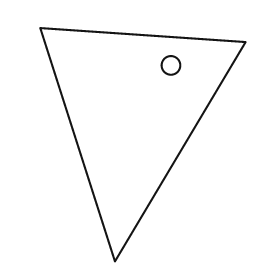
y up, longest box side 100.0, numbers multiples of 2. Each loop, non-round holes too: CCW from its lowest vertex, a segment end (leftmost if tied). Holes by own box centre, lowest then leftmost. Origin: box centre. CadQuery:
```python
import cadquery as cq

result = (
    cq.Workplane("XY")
    .moveTo(-12.0, -50.0)
    .lineTo(44.0, 44.0)
    .lineTo(-44.0, 50.0)
    .close()
    .moveTo(12.0, 34.0)
    .circle(4.0)
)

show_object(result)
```